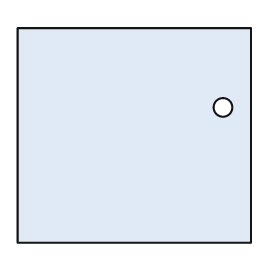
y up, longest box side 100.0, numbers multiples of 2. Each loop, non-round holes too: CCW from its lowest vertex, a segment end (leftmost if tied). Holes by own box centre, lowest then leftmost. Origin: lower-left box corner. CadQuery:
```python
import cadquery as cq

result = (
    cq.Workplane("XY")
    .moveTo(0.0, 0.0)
    .lineTo(100.0, 0.0)
    .lineTo(100.0, 92.0)
    .lineTo(0.0, 92.0)
    .close()
    .moveTo(88.0, 58.0)
    .circle(4.0)
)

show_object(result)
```